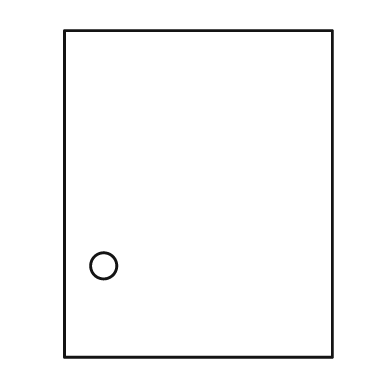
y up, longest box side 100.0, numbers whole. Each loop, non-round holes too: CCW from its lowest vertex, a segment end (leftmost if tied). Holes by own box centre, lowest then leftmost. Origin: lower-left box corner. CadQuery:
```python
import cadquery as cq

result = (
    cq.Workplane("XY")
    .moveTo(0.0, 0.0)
    .lineTo(82.0, 0.0)
    .lineTo(82.0, 100.0)
    .lineTo(0.0, 100.0)
    .close()
    .moveTo(12.0, 28.0)
    .circle(4.0)
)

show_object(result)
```